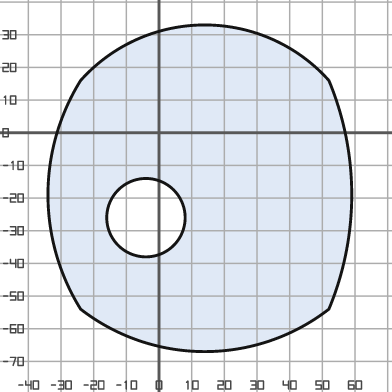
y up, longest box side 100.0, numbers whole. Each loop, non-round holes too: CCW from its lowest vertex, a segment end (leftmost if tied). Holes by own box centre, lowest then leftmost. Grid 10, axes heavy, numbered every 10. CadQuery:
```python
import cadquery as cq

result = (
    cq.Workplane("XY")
    .moveTo(-24.0, -54.0)
    .threePointArc((14.0, -67.0), (52.0, -54.0))
    .threePointArc((59.0, -19.0), (52.0, 16.0))
    .threePointArc((14.0, 33.0), (-24.0, 16.0))
    .threePointArc((-34.0, -19.0), (-24.0, -54.0))
    .close()
    .moveTo(-4.0, -26.0)
    .circle(12.0)
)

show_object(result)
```